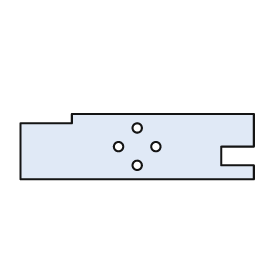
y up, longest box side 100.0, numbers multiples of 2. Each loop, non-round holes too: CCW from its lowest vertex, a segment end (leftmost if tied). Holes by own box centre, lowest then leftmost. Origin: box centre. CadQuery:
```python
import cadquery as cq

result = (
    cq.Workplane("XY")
    .moveTo(-50.0, -14.0)
    .lineTo(50.0, -14.0)
    .lineTo(50.0, -8.0)
    .lineTo(36.0, -8.0)
    .lineTo(36.0, 0.0)
    .lineTo(50.0, 0.0)
    .lineTo(50.0, 14.0)
    .lineTo(-28.0, 14.0)
    .lineTo(-28.0, 10.0)
    .lineTo(-50.0, 10.0)
    .close()
    .moveTo(0.0, -8.0)
    .circle(2.0)
    .moveTo(-8.0, 0.0)
    .circle(2.0)
    .moveTo(8.0, 0.0)
    .circle(2.0)
    .moveTo(0.0, 8.0)
    .circle(2.0)
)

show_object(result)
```